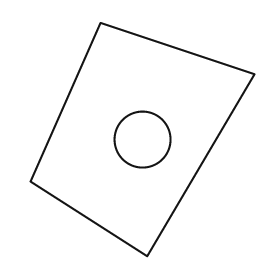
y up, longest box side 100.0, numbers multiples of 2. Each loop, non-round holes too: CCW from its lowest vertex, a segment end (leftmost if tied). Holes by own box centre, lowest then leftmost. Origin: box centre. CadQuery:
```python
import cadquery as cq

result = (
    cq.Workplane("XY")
    .moveTo(2.0, -50.0)
    .lineTo(48.0, 28.0)
    .lineTo(-18.0, 50.0)
    .lineTo(-48.0, -18.0)
    .close()
    .moveTo(0.0, 0.0)
    .circle(12.0)
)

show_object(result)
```